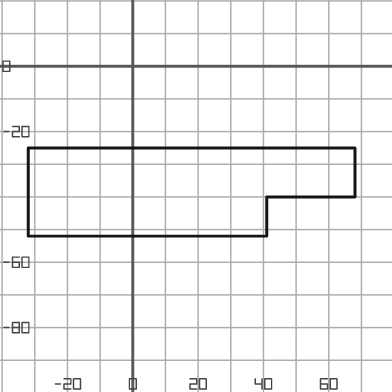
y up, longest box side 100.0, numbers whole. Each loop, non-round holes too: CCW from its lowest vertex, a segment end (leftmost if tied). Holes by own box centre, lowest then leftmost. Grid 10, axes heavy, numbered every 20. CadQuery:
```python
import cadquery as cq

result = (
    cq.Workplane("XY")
    .moveTo(-32.0, -52.0)
    .lineTo(41.0, -52.0)
    .lineTo(41.0, -40.0)
    .lineTo(68.0, -40.0)
    .lineTo(68.0, -25.0)
    .lineTo(-32.0, -25.0)
    .close()
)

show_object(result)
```